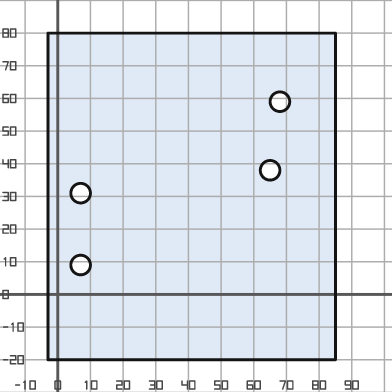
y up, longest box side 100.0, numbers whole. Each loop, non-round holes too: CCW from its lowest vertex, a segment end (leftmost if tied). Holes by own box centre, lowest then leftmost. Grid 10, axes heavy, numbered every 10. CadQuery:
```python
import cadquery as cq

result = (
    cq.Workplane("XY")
    .moveTo(-3.0, -20.0)
    .lineTo(85.0, -20.0)
    .lineTo(85.0, 80.0)
    .lineTo(-3.0, 80.0)
    .close()
    .moveTo(7.0, 9.0)
    .circle(3.0)
    .moveTo(7.0, 31.0)
    .circle(3.0)
    .moveTo(65.0, 38.0)
    .circle(3.0)
    .moveTo(68.0, 59.0)
    .circle(3.0)
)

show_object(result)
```